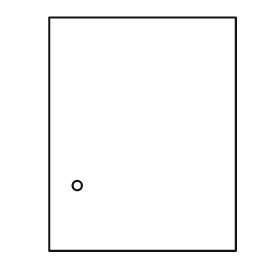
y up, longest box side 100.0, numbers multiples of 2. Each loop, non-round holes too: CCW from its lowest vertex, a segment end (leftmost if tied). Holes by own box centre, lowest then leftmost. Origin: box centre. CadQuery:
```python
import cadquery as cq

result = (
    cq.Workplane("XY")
    .moveTo(-40.0, -50.0)
    .lineTo(40.0, -50.0)
    .lineTo(40.0, 50.0)
    .lineTo(-40.0, 50.0)
    .close()
    .moveTo(-28.0, -22.0)
    .circle(2.0)
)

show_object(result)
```